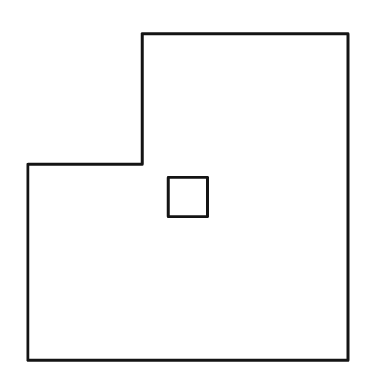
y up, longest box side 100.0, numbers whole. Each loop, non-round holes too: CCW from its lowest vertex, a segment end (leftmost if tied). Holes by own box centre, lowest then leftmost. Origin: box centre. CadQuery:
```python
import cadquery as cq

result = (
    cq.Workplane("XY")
    .moveTo(-49.0, -50.0)
    .lineTo(49.0, -50.0)
    .lineTo(49.0, 50.0)
    .lineTo(-14.0, 50.0)
    .lineTo(-14.0, 10.0)
    .lineTo(-49.0, 10.0)
    .close()
    .moveTo(-6.0, -6.0)
    .lineTo(6.0, -6.0)
    .lineTo(6.0, 6.0)
    .lineTo(-6.0, 6.0)
    .close()
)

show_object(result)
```